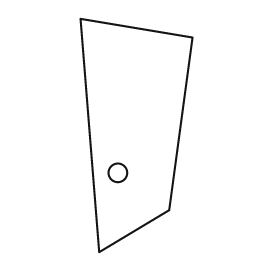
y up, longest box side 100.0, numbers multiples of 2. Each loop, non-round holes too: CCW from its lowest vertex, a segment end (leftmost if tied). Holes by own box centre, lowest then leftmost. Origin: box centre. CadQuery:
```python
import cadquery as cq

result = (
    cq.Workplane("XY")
    .moveTo(-16.0, -50.0)
    .lineTo(14.0, -32.0)
    .lineTo(24.0, 42.0)
    .lineTo(-24.0, 50.0)
    .close()
    .moveTo(-8.0, -16.0)
    .circle(4.0)
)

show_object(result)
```